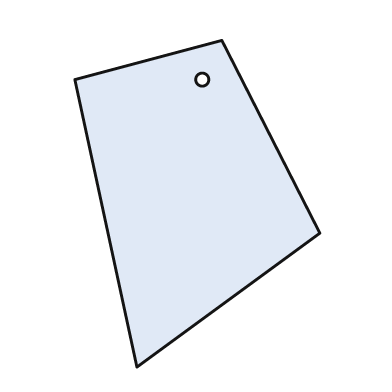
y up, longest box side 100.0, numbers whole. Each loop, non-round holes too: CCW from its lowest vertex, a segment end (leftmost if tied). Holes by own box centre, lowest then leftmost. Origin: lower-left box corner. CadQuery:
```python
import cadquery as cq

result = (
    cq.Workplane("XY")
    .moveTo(19.0, 0.0)
    .lineTo(75.0, 41.0)
    .lineTo(45.0, 100.0)
    .lineTo(0.0, 88.0)
    .close()
    .moveTo(39.0, 88.0)
    .circle(2.0)
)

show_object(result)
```